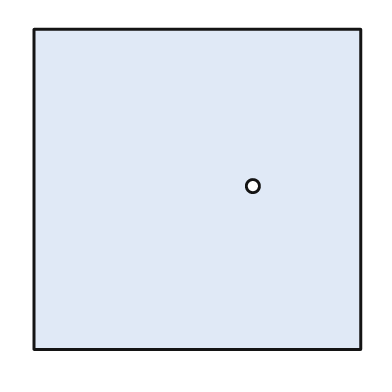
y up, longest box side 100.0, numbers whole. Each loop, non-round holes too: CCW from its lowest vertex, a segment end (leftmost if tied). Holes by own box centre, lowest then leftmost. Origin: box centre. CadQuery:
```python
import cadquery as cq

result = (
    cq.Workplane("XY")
    .moveTo(-50.0, -49.0)
    .lineTo(50.0, -49.0)
    .lineTo(50.0, 49.0)
    .lineTo(-50.0, 49.0)
    .close()
    .moveTo(17.0, 1.0)
    .circle(2.0)
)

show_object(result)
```